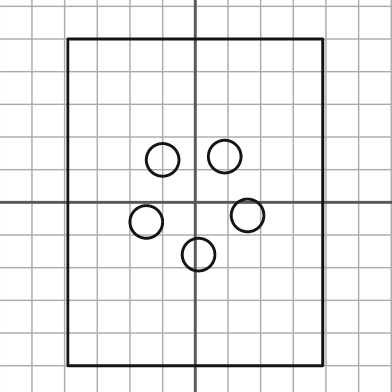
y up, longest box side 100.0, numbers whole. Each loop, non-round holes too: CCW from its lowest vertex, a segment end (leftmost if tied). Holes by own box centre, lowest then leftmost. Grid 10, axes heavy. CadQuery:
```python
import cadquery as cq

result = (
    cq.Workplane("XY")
    .moveTo(-39.0, -50.0)
    .lineTo(39.0, -50.0)
    .lineTo(39.0, 50.0)
    .lineTo(-39.0, 50.0)
    .close()
    .moveTo(1.0, -16.0)
    .circle(5.0)
    .moveTo(-15.0, -6.0)
    .circle(5.0)
    .moveTo(16.0, -4.0)
    .circle(5.0)
    .moveTo(-10.0, 13.0)
    .circle(5.0)
    .moveTo(9.0, 14.0)
    .circle(5.0)
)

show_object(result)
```